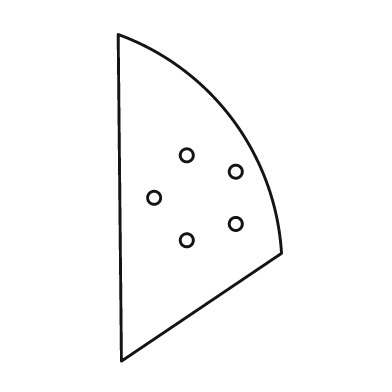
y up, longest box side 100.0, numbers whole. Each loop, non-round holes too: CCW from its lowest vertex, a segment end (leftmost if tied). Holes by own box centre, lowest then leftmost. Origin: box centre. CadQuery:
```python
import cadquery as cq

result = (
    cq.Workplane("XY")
    .moveTo(-24.0, -50.0)
    .lineTo(25.0, -17.0)
    .threePointArc((10.0, 24.0), (-25.0, 50.0))
    .close()
    .moveTo(-4.0, -13.0)
    .circle(2.0)
    .moveTo(11.0, -8.0)
    .circle(2.0)
    .moveTo(-14.0, 0.0)
    .circle(2.0)
    .moveTo(11.0, 8.0)
    .circle(2.0)
    .moveTo(-4.0, 13.0)
    .circle(2.0)
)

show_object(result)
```